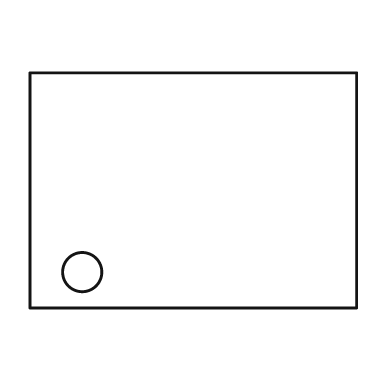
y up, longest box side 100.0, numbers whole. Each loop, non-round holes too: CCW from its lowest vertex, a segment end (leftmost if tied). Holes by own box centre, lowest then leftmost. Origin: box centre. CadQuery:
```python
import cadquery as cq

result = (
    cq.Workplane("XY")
    .moveTo(-50.0, -36.0)
    .lineTo(50.0, -36.0)
    .lineTo(50.0, 36.0)
    .lineTo(-50.0, 36.0)
    .close()
    .moveTo(-34.0, -25.0)
    .circle(6.0)
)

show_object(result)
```